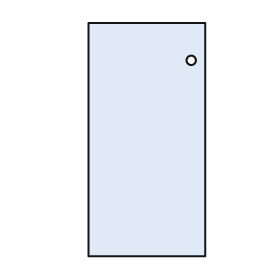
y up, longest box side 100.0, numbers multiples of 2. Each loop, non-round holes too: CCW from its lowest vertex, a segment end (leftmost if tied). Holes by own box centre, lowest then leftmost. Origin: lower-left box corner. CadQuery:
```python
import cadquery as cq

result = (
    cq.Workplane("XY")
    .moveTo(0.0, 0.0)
    .lineTo(50.0, 0.0)
    .lineTo(50.0, 100.0)
    .lineTo(0.0, 100.0)
    .close()
    .moveTo(44.0, 84.0)
    .circle(2.0)
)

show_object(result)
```